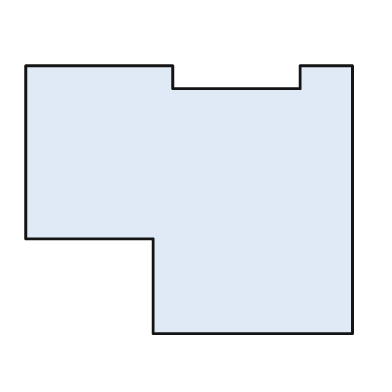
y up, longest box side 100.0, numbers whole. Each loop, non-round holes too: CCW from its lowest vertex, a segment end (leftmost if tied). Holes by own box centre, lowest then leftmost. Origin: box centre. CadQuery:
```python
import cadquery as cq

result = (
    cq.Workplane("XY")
    .moveTo(-11.0, -41.0)
    .lineTo(50.0, -41.0)
    .lineTo(50.0, 41.0)
    .lineTo(34.0, 41.0)
    .lineTo(34.0, 34.0)
    .lineTo(-5.0, 34.0)
    .lineTo(-5.0, 41.0)
    .lineTo(-50.0, 41.0)
    .lineTo(-50.0, -12.0)
    .lineTo(-11.0, -12.0)
    .close()
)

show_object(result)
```